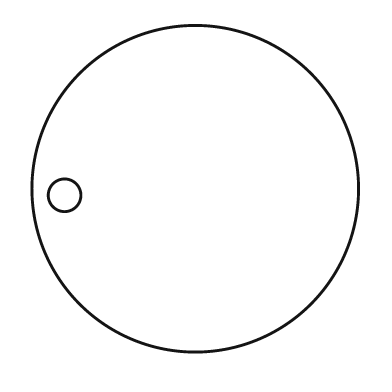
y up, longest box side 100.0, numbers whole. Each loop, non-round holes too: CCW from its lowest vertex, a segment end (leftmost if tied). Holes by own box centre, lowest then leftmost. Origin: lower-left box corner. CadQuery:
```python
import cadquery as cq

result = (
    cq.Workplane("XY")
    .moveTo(50.0, 50.0)
    .circle(50.0)
    .moveTo(10.0, 48.0)
    .circle(5.0)
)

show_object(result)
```